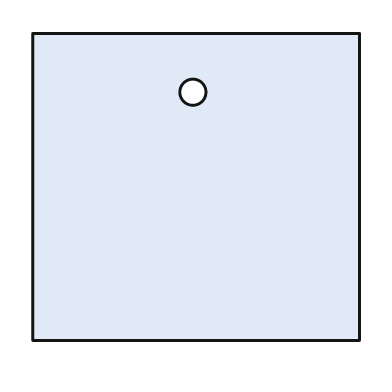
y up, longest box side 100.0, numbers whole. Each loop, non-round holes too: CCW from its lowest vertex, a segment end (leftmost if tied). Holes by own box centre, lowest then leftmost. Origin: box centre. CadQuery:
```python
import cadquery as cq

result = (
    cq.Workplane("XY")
    .moveTo(-50.0, -47.0)
    .lineTo(50.0, -47.0)
    .lineTo(50.0, 47.0)
    .lineTo(-50.0, 47.0)
    .close()
    .moveTo(-1.0, 29.0)
    .circle(4.0)
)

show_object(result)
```